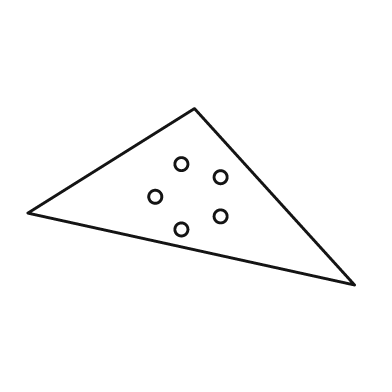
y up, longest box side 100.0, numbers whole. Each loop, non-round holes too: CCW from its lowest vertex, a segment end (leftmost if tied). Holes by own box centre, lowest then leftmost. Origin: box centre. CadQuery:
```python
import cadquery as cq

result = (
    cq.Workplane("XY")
    .moveTo(50.0, -27.0)
    .lineTo(1.0, 27.0)
    .lineTo(-50.0, -5.0)
    .close()
    .moveTo(-3.0, -10.0)
    .circle(2.0)
    .moveTo(9.0, -6.0)
    .circle(2.0)
    .moveTo(-11.0, 0.0)
    .circle(2.0)
    .moveTo(9.0, 6.0)
    .circle(2.0)
    .moveTo(-3.0, 10.0)
    .circle(2.0)
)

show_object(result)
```